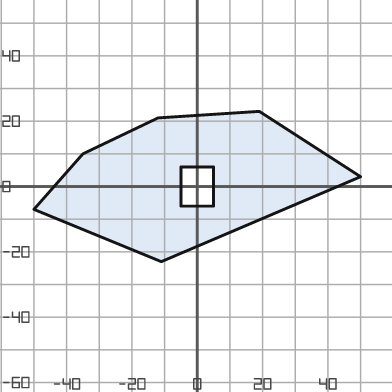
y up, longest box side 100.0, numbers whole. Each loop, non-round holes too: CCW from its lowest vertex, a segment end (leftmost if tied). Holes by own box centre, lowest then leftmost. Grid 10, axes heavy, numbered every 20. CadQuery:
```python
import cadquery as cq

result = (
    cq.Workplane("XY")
    .moveTo(-11.0, -23.0)
    .lineTo(50.0, 3.0)
    .lineTo(19.0, 23.0)
    .lineTo(-12.0, 21.0)
    .lineTo(-35.0, 10.0)
    .lineTo(-50.0, -7.0)
    .close()
    .moveTo(-5.0, -6.0)
    .lineTo(5.0, -6.0)
    .lineTo(5.0, 6.0)
    .lineTo(-5.0, 6.0)
    .close()
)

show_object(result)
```